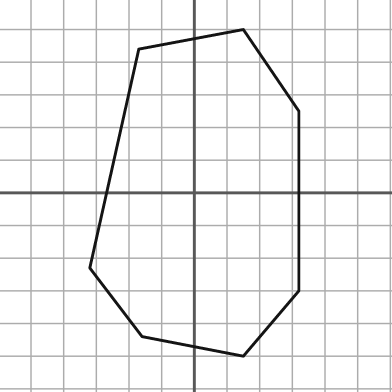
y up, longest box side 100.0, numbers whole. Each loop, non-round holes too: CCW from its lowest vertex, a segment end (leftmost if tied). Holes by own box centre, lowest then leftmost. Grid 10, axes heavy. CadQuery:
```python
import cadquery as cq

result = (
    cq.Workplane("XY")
    .moveTo(15.0, -50.0)
    .lineTo(32.0, -30.0)
    .lineTo(32.0, 25.0)
    .lineTo(15.0, 50.0)
    .lineTo(-17.0, 44.0)
    .lineTo(-32.0, -23.0)
    .lineTo(-16.0, -44.0)
    .close()
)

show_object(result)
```